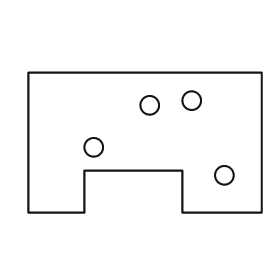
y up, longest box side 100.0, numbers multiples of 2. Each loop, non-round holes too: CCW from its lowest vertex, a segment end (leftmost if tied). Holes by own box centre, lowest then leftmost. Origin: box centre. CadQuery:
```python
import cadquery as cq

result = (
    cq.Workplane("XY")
    .moveTo(-50.0, -30.0)
    .lineTo(-26.0, -30.0)
    .lineTo(-26.0, -12.0)
    .lineTo(16.0, -12.0)
    .lineTo(16.0, -30.0)
    .lineTo(50.0, -30.0)
    .lineTo(50.0, 30.0)
    .lineTo(-50.0, 30.0)
    .close()
    .moveTo(34.0, -14.0)
    .circle(4.0)
    .moveTo(-22.0, -2.0)
    .circle(4.0)
    .moveTo(2.0, 16.0)
    .circle(4.0)
    .moveTo(20.0, 18.0)
    .circle(4.0)
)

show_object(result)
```